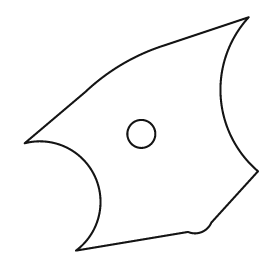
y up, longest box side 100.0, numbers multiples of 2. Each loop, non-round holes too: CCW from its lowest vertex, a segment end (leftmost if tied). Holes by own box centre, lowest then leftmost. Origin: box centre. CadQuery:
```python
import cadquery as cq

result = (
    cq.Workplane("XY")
    .moveTo(-28.0, -50.0)
    .lineTo(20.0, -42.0)
    .threePointArc((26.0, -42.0), (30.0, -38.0))
    .lineTo(50.0, -16.0)
    .threePointArc((34.0, 16.0), (46.0, 50.0))
    .lineTo(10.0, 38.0)
    .threePointArc((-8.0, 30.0), (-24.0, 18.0))
    .lineTo(-50.0, -4.0)
    .threePointArc((-20.0, -18.0), (-28.0, -50.0))
    .close()
    .moveTo(0.0, 0.0)
    .circle(6.0)
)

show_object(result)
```